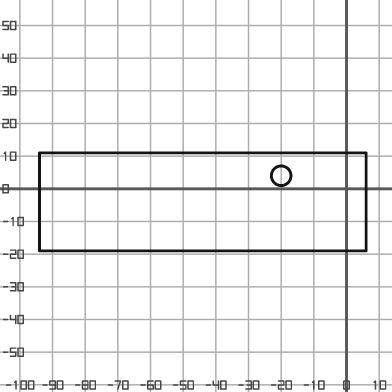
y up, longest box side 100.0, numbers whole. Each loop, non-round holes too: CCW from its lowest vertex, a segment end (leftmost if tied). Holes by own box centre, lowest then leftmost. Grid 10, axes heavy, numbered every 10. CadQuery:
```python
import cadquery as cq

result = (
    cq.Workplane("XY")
    .moveTo(-94.0, -19.0)
    .lineTo(6.0, -19.0)
    .lineTo(6.0, 11.0)
    .lineTo(-94.0, 11.0)
    .close()
    .moveTo(-20.0, 4.0)
    .circle(3.0)
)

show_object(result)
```